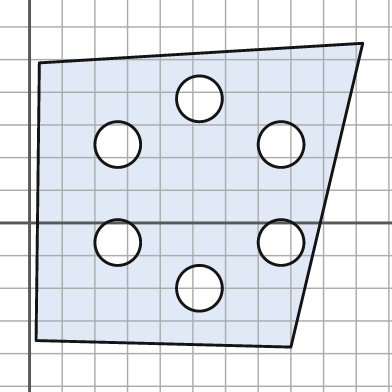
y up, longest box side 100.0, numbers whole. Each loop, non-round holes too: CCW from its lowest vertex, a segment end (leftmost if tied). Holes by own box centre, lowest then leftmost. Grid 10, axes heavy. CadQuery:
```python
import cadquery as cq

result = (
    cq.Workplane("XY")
    .moveTo(80.0, -38.0)
    .lineTo(102.0, 55.0)
    .lineTo(3.0, 49.0)
    .lineTo(2.0, -36.0)
    .close()
    .moveTo(52.0, -20.0)
    .circle(7.0)
    .moveTo(27.0, -6.0)
    .circle(7.0)
    .moveTo(77.0, -6.0)
    .circle(7.0)
    .moveTo(27.0, 24.0)
    .circle(7.0)
    .moveTo(77.0, 24.0)
    .circle(7.0)
    .moveTo(52.0, 38.0)
    .circle(7.0)
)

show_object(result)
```